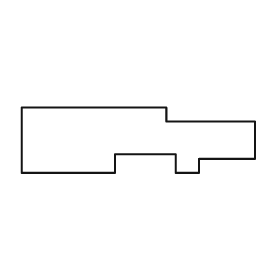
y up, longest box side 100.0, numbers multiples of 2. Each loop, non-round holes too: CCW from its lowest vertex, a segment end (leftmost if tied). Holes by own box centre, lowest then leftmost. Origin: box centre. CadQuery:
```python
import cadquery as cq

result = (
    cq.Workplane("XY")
    .moveTo(-50.0, -14.0)
    .lineTo(-10.0, -14.0)
    .lineTo(-10.0, -6.0)
    .lineTo(16.0, -6.0)
    .lineTo(16.0, -14.0)
    .lineTo(26.0, -14.0)
    .lineTo(26.0, -8.0)
    .lineTo(50.0, -8.0)
    .lineTo(50.0, 8.0)
    .lineTo(12.0, 8.0)
    .lineTo(12.0, 14.0)
    .lineTo(-50.0, 14.0)
    .close()
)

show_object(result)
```